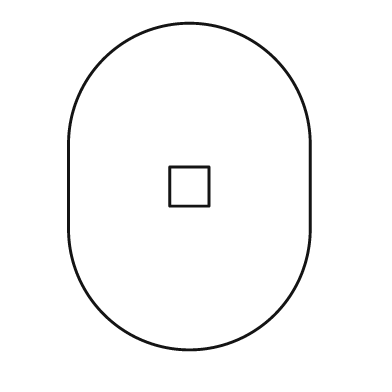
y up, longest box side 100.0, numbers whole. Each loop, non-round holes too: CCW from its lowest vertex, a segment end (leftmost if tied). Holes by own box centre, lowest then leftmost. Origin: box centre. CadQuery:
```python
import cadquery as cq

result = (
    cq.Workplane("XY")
    .moveTo(-37.0, -13.0)
    .threePointArc((0.0, -50.0), (37.0, -13.0))
    .lineTo(37.0, 13.0)
    .threePointArc((0.0, 50.0), (-37.0, 13.0))
    .close()
    .moveTo(-6.0, -6.0)
    .lineTo(6.0, -6.0)
    .lineTo(6.0, 6.0)
    .lineTo(-6.0, 6.0)
    .close()
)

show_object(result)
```